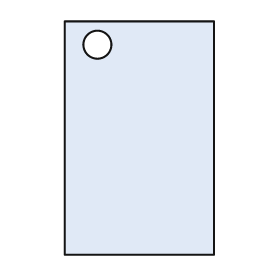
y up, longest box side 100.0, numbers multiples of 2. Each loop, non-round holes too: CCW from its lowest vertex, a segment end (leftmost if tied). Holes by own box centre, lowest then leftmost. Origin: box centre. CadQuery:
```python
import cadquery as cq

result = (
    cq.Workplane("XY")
    .moveTo(-32.0, -50.0)
    .lineTo(32.0, -50.0)
    .lineTo(32.0, 50.0)
    .lineTo(-32.0, 50.0)
    .close()
    .moveTo(-18.0, 40.0)
    .circle(6.0)
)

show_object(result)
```